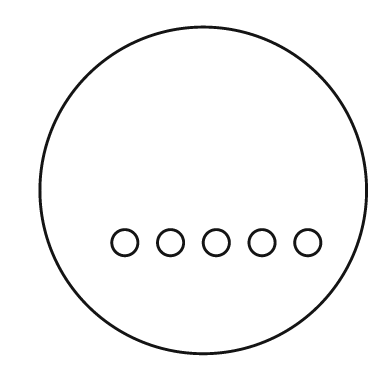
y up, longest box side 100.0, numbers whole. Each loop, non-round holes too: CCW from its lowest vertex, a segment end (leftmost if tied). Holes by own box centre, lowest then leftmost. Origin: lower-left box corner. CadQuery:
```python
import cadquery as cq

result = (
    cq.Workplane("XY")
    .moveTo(50.0, 50.0)
    .circle(50.0)
    .moveTo(26.0, 34.0)
    .circle(4.0)
    .moveTo(40.0, 34.0)
    .circle(4.0)
    .moveTo(54.0, 34.0)
    .circle(4.0)
    .moveTo(68.0, 34.0)
    .circle(4.0)
    .moveTo(82.0, 34.0)
    .circle(4.0)
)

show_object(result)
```